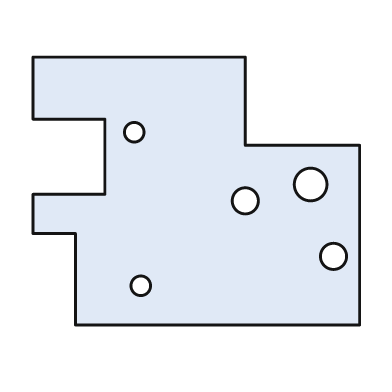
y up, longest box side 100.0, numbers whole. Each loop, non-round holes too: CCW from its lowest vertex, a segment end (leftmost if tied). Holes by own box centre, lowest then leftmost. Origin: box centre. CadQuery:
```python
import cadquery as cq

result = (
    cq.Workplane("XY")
    .moveTo(-37.0, -41.0)
    .lineTo(50.0, -41.0)
    .lineTo(50.0, 14.0)
    .lineTo(15.0, 14.0)
    .lineTo(15.0, 41.0)
    .lineTo(-50.0, 41.0)
    .lineTo(-50.0, 22.0)
    .lineTo(-28.0, 22.0)
    .lineTo(-28.0, -1.0)
    .lineTo(-50.0, -1.0)
    .lineTo(-50.0, -13.0)
    .lineTo(-37.0, -13.0)
    .close()
    .moveTo(-17.0, -29.0)
    .circle(3.0)
    .moveTo(42.0, -20.0)
    .circle(4.0)
    .moveTo(15.0, -3.0)
    .circle(4.0)
    .moveTo(35.0, 2.0)
    .circle(5.0)
    .moveTo(-19.0, 18.0)
    .circle(3.0)
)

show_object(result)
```